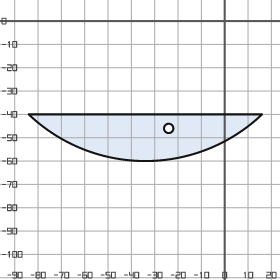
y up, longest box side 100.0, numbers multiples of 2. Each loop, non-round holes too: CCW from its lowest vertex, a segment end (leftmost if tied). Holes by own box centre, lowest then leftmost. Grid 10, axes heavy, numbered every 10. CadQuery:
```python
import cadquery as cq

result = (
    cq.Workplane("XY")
    .moveTo(-84.0, -40.0)
    .threePointArc((-34.0, -60.0), (16.0, -40.0))
    .close()
    .moveTo(-24.0, -46.0)
    .circle(2.0)
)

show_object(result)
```